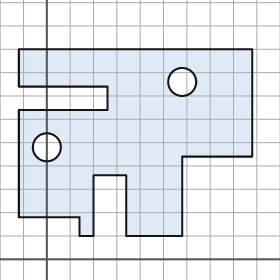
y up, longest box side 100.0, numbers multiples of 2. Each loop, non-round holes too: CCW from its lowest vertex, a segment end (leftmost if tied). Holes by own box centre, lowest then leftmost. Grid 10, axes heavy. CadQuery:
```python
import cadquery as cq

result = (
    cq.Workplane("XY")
    .moveTo(14.0, 10.0)
    .lineTo(20.0, 10.0)
    .lineTo(20.0, 36.0)
    .lineTo(34.0, 36.0)
    .lineTo(34.0, 10.0)
    .lineTo(58.0, 10.0)
    .lineTo(58.0, 44.0)
    .lineTo(88.0, 44.0)
    .lineTo(88.0, 90.0)
    .lineTo(-12.0, 90.0)
    .lineTo(-12.0, 74.0)
    .lineTo(26.0, 74.0)
    .lineTo(26.0, 64.0)
    .lineTo(-12.0, 64.0)
    .lineTo(-12.0, 18.0)
    .lineTo(14.0, 18.0)
    .close()
    .moveTo(0.0, 48.0)
    .circle(6.0)
    .moveTo(58.0, 76.0)
    .circle(6.0)
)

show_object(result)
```